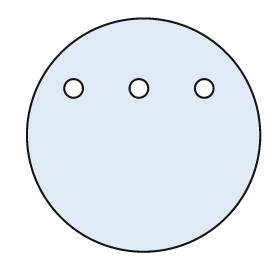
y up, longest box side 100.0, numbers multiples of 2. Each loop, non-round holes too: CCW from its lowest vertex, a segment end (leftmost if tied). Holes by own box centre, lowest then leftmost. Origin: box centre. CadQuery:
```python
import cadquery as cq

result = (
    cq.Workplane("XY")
    .moveTo(0.0, 0.0)
    .circle(50.0)
    .moveTo(-30.0, 20.0)
    .circle(4.0)
    .moveTo(-2.0, 20.0)
    .circle(4.0)
    .moveTo(26.0, 20.0)
    .circle(4.0)
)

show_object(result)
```